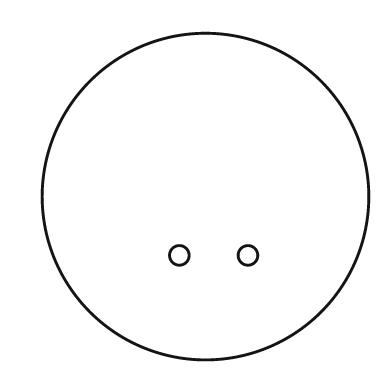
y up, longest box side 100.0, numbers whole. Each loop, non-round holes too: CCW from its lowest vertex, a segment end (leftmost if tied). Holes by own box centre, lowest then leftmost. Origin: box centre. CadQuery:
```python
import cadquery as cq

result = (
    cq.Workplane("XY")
    .moveTo(0.0, 0.0)
    .circle(50.0)
    .moveTo(-8.0, -18.0)
    .circle(3.0)
    .moveTo(13.0, -18.0)
    .circle(3.0)
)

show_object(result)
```